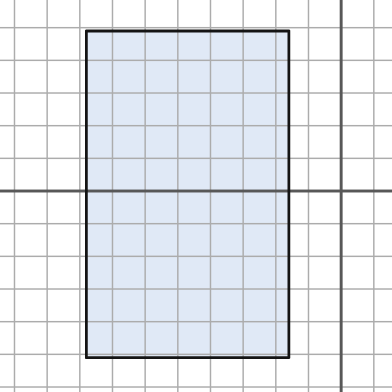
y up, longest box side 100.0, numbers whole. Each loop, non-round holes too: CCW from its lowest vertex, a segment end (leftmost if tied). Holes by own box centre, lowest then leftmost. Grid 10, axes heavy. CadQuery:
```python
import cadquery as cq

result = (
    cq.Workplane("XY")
    .moveTo(-78.0, -51.0)
    .lineTo(-16.0, -51.0)
    .lineTo(-16.0, 49.0)
    .lineTo(-78.0, 49.0)
    .close()
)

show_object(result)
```